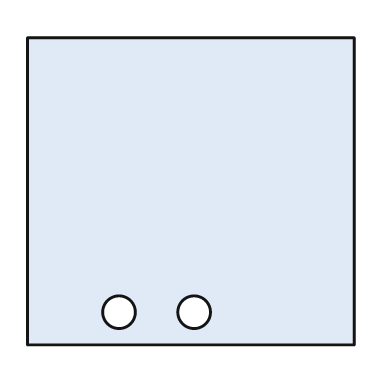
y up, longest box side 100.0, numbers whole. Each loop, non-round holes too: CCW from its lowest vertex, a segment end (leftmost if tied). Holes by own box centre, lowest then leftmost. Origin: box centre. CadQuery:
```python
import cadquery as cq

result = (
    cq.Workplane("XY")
    .moveTo(-50.0, -47.0)
    .lineTo(50.0, -47.0)
    .lineTo(50.0, 47.0)
    .lineTo(-50.0, 47.0)
    .close()
    .moveTo(-22.0, -37.0)
    .circle(5.0)
    .moveTo(1.0, -37.0)
    .circle(5.0)
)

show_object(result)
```